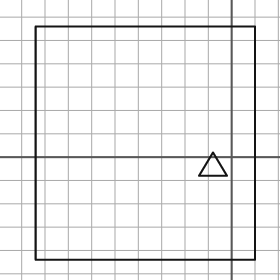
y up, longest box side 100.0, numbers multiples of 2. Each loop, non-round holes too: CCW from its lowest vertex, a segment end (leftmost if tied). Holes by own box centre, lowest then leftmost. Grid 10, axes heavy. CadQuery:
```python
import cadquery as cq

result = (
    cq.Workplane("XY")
    .moveTo(-84.0, -44.0)
    .lineTo(10.0, -44.0)
    .lineTo(10.0, 56.0)
    .lineTo(-84.0, 56.0)
    .close()
    .moveTo(-14.0, -8.0)
    .lineTo(-2.0, -8.0)
    .lineTo(-8.0, 2.0)
    .close()
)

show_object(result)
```